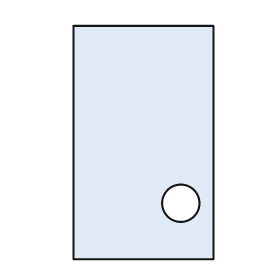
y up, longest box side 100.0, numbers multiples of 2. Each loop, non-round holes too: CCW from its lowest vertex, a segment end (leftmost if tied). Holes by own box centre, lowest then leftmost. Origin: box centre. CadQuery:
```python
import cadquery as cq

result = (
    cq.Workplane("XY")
    .moveTo(-30.0, -50.0)
    .lineTo(30.0, -50.0)
    .lineTo(30.0, 50.0)
    .lineTo(-30.0, 50.0)
    .close()
    .moveTo(16.0, -26.0)
    .circle(8.0)
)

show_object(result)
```